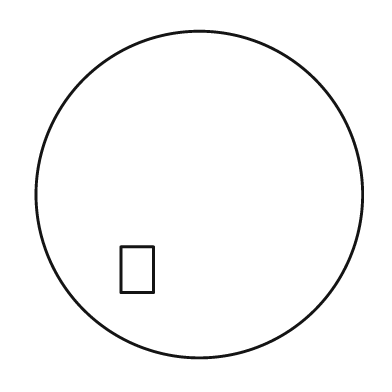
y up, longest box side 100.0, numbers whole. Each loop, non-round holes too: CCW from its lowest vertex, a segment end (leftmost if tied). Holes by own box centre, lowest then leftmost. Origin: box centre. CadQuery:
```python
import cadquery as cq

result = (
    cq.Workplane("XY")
    .moveTo(0.0, 0.0)
    .circle(50.0)
    .moveTo(-24.0, -30.0)
    .lineTo(-14.0, -30.0)
    .lineTo(-14.0, -16.0)
    .lineTo(-24.0, -16.0)
    .close()
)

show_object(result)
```